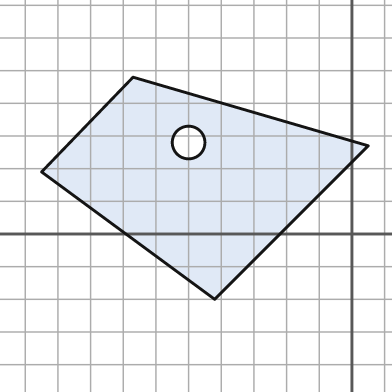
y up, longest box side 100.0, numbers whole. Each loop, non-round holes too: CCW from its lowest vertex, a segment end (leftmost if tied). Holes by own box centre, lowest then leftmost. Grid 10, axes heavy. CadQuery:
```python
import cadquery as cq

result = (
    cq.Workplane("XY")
    .moveTo(-42.0, -20.0)
    .lineTo(5.0, 27.0)
    .lineTo(-67.0, 48.0)
    .lineTo(-95.0, 19.0)
    .close()
    .moveTo(-50.0, 28.0)
    .circle(5.0)
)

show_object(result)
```